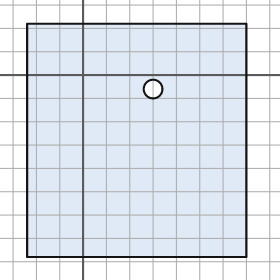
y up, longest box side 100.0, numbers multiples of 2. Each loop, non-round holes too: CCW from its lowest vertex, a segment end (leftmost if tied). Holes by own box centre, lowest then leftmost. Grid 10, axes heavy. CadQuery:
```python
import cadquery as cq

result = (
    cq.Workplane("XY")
    .moveTo(-24.0, -78.0)
    .lineTo(70.0, -78.0)
    .lineTo(70.0, 22.0)
    .lineTo(-24.0, 22.0)
    .close()
    .moveTo(30.0, -6.0)
    .circle(4.0)
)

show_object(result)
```